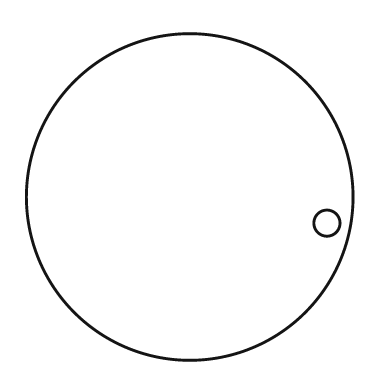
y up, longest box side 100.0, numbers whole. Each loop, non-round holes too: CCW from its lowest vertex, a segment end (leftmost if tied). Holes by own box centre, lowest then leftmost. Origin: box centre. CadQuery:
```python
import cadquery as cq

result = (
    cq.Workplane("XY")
    .moveTo(0.0, 0.0)
    .circle(50.0)
    .moveTo(42.0, -8.0)
    .circle(4.0)
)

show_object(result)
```